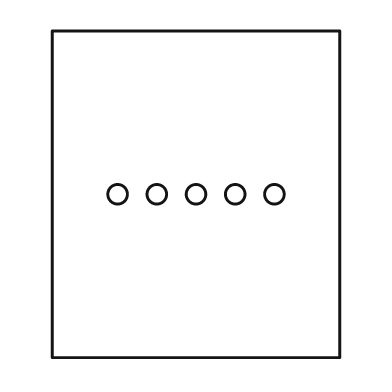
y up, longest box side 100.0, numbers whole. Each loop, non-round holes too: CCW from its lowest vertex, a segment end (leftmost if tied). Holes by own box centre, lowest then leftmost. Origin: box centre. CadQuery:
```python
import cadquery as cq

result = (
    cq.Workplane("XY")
    .moveTo(-44.0, -50.0)
    .lineTo(44.0, -50.0)
    .lineTo(44.0, 50.0)
    .lineTo(-44.0, 50.0)
    .close()
    .moveTo(-24.0, 0.0)
    .circle(3.0)
    .moveTo(-12.0, 0.0)
    .circle(3.0)
    .moveTo(0.0, 0.0)
    .circle(3.0)
    .moveTo(12.0, 0.0)
    .circle(3.0)
    .moveTo(24.0, 0.0)
    .circle(3.0)
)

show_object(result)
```